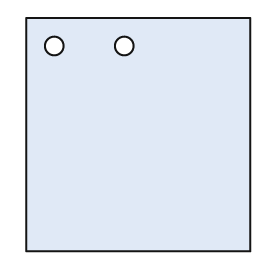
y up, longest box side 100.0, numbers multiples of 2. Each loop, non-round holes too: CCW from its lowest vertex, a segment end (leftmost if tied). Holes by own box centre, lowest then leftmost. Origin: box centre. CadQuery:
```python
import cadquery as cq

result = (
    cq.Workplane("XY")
    .moveTo(-48.0, -50.0)
    .lineTo(48.0, -50.0)
    .lineTo(48.0, 50.0)
    .lineTo(-48.0, 50.0)
    .close()
    .moveTo(-36.0, 38.0)
    .circle(4.0)
    .moveTo(-6.0, 38.0)
    .circle(4.0)
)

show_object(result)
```